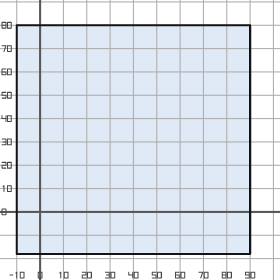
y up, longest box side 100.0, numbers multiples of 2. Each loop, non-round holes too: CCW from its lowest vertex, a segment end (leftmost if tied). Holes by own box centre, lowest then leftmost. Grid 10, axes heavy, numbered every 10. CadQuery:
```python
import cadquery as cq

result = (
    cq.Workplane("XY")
    .moveTo(-10.0, -18.0)
    .lineTo(90.0, -18.0)
    .lineTo(90.0, 80.0)
    .lineTo(-10.0, 80.0)
    .close()
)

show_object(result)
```